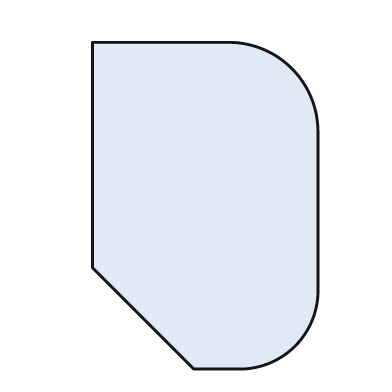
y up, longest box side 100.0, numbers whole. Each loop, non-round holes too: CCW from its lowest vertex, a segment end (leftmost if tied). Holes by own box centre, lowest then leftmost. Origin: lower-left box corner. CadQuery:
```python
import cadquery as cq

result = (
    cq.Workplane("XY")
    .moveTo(31.0, 0.0)
    .lineTo(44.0, 0.0)
    .threePointArc((62.0, 7.0), (69.0, 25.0))
    .lineTo(69.0, 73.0)
    .threePointArc((61.0, 92.0), (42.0, 100.0))
    .lineTo(0.0, 100.0)
    .lineTo(0.0, 31.0)
    .close()
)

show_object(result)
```